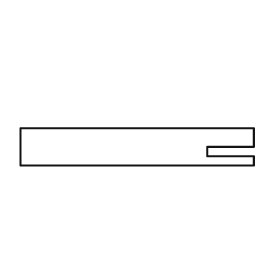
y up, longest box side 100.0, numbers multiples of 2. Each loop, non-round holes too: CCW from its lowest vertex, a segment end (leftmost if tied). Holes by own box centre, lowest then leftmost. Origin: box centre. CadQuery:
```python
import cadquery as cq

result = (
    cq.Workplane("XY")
    .moveTo(-50.0, -8.0)
    .lineTo(50.0, -8.0)
    .lineTo(50.0, -4.0)
    .lineTo(30.0, -4.0)
    .lineTo(30.0, 0.0)
    .lineTo(50.0, 0.0)
    .lineTo(50.0, 8.0)
    .lineTo(-50.0, 8.0)
    .close()
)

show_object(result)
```